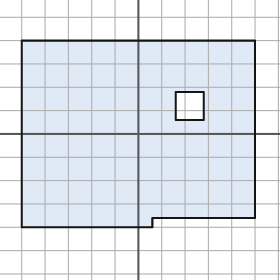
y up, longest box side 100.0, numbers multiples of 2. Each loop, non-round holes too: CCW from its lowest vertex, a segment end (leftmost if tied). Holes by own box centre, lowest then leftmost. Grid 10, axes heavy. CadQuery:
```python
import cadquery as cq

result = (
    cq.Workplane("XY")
    .moveTo(-50.0, -40.0)
    .lineTo(6.0, -40.0)
    .lineTo(6.0, -36.0)
    .lineTo(50.0, -36.0)
    .lineTo(50.0, 40.0)
    .lineTo(-50.0, 40.0)
    .close()
    .moveTo(16.0, 6.0)
    .lineTo(28.0, 6.0)
    .lineTo(28.0, 18.0)
    .lineTo(16.0, 18.0)
    .close()
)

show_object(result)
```